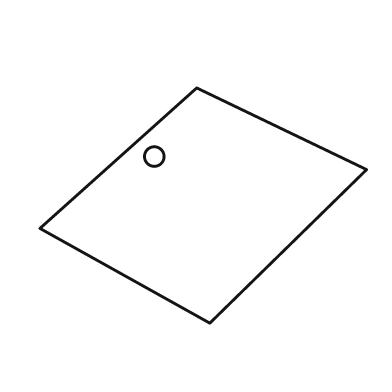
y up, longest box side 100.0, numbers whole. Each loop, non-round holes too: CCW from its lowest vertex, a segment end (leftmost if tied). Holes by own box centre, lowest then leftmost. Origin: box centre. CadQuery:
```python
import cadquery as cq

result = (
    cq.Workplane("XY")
    .moveTo(2.0, -36.0)
    .lineTo(50.0, 11.0)
    .lineTo(-2.0, 36.0)
    .lineTo(-50.0, -7.0)
    .close()
    .moveTo(-15.0, 15.0)
    .circle(3.0)
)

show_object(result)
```